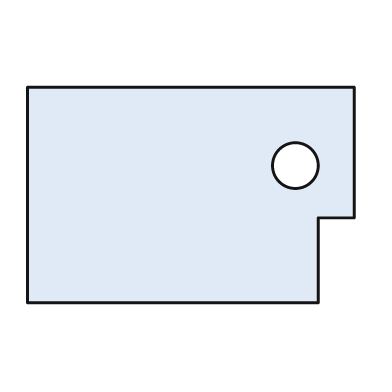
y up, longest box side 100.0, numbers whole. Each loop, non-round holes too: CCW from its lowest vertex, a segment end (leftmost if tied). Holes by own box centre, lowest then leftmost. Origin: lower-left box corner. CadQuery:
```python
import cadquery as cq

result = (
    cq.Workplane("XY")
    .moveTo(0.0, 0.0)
    .lineTo(89.0, 0.0)
    .lineTo(89.0, 26.0)
    .lineTo(100.0, 26.0)
    .lineTo(100.0, 66.0)
    .lineTo(0.0, 66.0)
    .close()
    .moveTo(82.0, 42.0)
    .circle(7.0)
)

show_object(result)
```